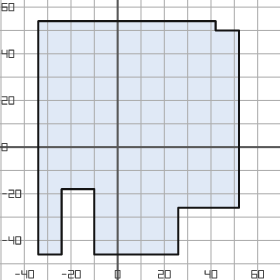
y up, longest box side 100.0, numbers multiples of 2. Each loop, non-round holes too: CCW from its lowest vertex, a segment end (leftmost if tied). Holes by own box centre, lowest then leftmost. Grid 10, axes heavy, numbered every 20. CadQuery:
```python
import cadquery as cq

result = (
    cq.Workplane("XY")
    .moveTo(-34.0, -46.0)
    .lineTo(-24.0, -46.0)
    .lineTo(-24.0, -18.0)
    .lineTo(-10.0, -18.0)
    .lineTo(-10.0, -46.0)
    .lineTo(26.0, -46.0)
    .lineTo(26.0, -26.0)
    .lineTo(52.0, -26.0)
    .lineTo(52.0, 50.0)
    .lineTo(42.0, 50.0)
    .lineTo(42.0, 54.0)
    .lineTo(-34.0, 54.0)
    .close()
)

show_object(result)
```